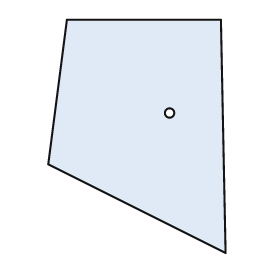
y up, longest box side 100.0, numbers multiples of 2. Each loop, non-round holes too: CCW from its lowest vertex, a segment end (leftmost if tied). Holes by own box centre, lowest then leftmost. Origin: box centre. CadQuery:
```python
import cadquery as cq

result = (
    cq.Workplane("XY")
    .moveTo(38.0, -50.0)
    .lineTo(36.0, 50.0)
    .lineTo(-30.0, 50.0)
    .lineTo(-38.0, -12.0)
    .close()
    .moveTo(14.0, 10.0)
    .circle(2.0)
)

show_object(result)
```